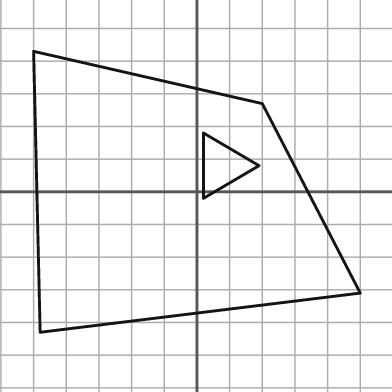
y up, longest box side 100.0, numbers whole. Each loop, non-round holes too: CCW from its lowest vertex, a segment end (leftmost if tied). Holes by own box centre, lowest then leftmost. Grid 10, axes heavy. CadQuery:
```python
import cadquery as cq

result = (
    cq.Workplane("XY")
    .moveTo(-48.0, -43.0)
    .lineTo(50.0, -31.0)
    .lineTo(20.0, 27.0)
    .lineTo(-50.0, 43.0)
    .close()
    .moveTo(2.0, -2.0)
    .lineTo(19.0, 8.0)
    .lineTo(2.0, 18.0)
    .close()
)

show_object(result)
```